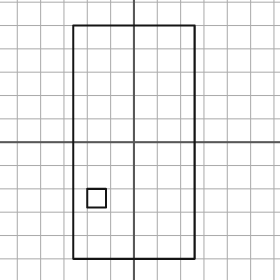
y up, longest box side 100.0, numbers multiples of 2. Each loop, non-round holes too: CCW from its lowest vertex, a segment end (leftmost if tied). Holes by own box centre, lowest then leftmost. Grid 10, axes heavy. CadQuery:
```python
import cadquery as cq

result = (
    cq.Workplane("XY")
    .moveTo(-26.0, -50.0)
    .lineTo(26.0, -50.0)
    .lineTo(26.0, 50.0)
    .lineTo(-26.0, 50.0)
    .close()
    .moveTo(-20.0, -28.0)
    .lineTo(-12.0, -28.0)
    .lineTo(-12.0, -20.0)
    .lineTo(-20.0, -20.0)
    .close()
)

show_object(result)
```